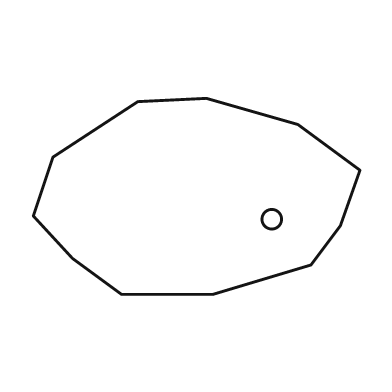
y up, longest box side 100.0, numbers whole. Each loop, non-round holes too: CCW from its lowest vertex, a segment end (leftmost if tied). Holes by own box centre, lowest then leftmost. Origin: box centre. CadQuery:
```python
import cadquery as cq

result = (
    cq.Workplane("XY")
    .moveTo(-23.0, -30.0)
    .lineTo(5.0, -30.0)
    .lineTo(35.0, -21.0)
    .lineTo(44.0, -9.0)
    .lineTo(50.0, 8.0)
    .lineTo(31.0, 22.0)
    .lineTo(3.0, 30.0)
    .lineTo(-18.0, 29.0)
    .lineTo(-44.0, 12.0)
    .lineTo(-50.0, -6.0)
    .lineTo(-38.0, -19.0)
    .close()
    .moveTo(23.0, -7.0)
    .circle(3.0)
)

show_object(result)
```